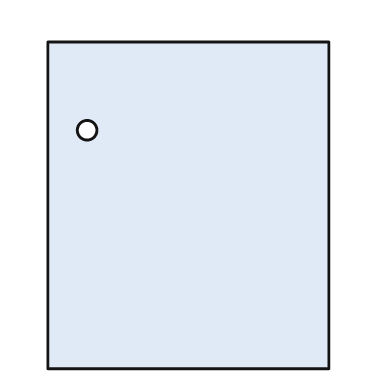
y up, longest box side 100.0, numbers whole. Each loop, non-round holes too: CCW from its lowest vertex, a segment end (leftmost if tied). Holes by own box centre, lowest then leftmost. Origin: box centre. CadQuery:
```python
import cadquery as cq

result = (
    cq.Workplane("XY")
    .moveTo(-43.0, -50.0)
    .lineTo(43.0, -50.0)
    .lineTo(43.0, 50.0)
    .lineTo(-43.0, 50.0)
    .close()
    .moveTo(-31.0, 23.0)
    .circle(3.0)
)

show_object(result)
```